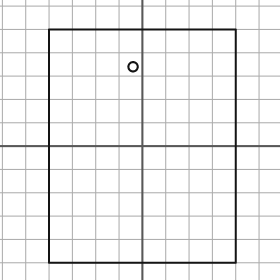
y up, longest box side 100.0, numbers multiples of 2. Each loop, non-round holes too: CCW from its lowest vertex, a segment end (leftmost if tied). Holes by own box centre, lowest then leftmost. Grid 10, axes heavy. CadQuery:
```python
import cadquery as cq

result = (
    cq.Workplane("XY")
    .moveTo(-40.0, -50.0)
    .lineTo(40.0, -50.0)
    .lineTo(40.0, 50.0)
    .lineTo(-40.0, 50.0)
    .close()
    .moveTo(-4.0, 34.0)
    .circle(2.0)
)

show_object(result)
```